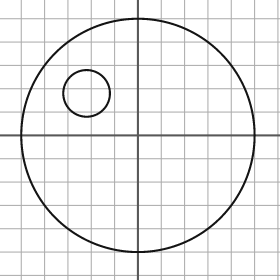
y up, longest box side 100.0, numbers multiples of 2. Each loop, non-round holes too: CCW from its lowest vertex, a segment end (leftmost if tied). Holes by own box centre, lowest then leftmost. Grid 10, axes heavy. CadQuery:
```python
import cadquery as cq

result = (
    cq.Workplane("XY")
    .moveTo(0.0, 0.0)
    .circle(50.0)
    .moveTo(-22.0, 18.0)
    .circle(10.0)
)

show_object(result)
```